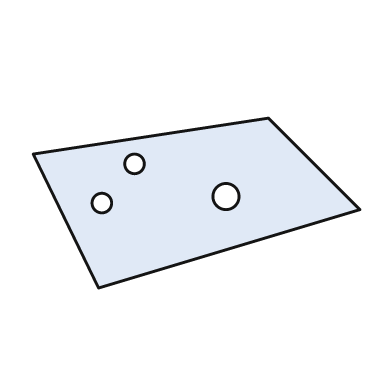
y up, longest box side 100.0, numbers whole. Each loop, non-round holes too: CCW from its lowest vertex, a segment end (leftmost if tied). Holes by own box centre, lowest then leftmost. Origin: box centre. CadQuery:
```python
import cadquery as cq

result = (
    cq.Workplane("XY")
    .moveTo(-30.0, -26.0)
    .lineTo(50.0, -2.0)
    .lineTo(22.0, 26.0)
    .lineTo(-50.0, 15.0)
    .close()
    .moveTo(-29.0, 0.0)
    .circle(3.0)
    .moveTo(9.0, 2.0)
    .circle(4.0)
    .moveTo(-19.0, 12.0)
    .circle(3.0)
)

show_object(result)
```